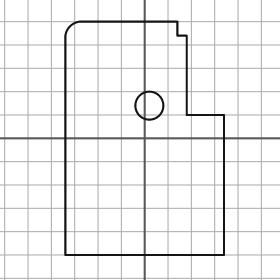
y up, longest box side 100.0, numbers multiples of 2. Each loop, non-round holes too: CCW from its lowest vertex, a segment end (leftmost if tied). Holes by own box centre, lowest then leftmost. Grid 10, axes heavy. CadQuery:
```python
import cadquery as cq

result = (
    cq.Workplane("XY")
    .moveTo(-34.0, -50.0)
    .lineTo(34.0, -50.0)
    .lineTo(34.0, 10.0)
    .lineTo(18.0, 10.0)
    .lineTo(18.0, 44.0)
    .lineTo(14.0, 44.0)
    .lineTo(14.0, 50.0)
    .lineTo(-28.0, 50.0)
    .threePointArc((-32.0, 48.0), (-34.0, 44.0))
    .close()
    .moveTo(2.0, 14.0)
    .circle(6.0)
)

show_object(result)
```